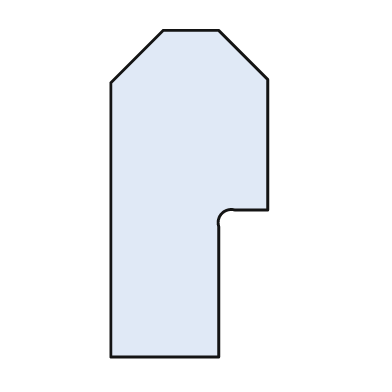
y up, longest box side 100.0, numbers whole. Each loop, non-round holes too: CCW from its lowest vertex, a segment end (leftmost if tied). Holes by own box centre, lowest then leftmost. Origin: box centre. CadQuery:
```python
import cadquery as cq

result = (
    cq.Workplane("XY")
    .moveTo(-24.0, -50.0)
    .lineTo(9.0, -50.0)
    .lineTo(9.0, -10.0)
    .threePointArc((10.0, -6.0), (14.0, -5.0))
    .lineTo(24.0, -5.0)
    .lineTo(24.0, 35.0)
    .lineTo(9.0, 50.0)
    .lineTo(-8.0, 50.0)
    .lineTo(-24.0, 34.0)
    .close()
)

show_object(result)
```